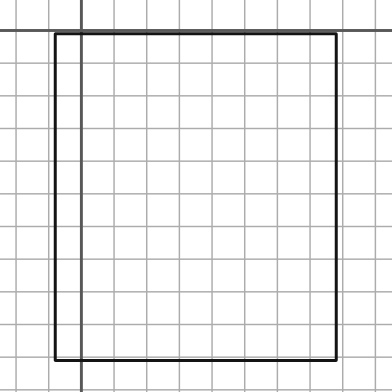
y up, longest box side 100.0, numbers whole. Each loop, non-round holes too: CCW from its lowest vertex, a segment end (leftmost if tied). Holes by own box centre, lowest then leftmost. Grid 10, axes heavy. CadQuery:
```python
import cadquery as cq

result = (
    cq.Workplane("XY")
    .moveTo(-8.0, -101.0)
    .lineTo(78.0, -101.0)
    .lineTo(78.0, -1.0)
    .lineTo(-8.0, -1.0)
    .close()
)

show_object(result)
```